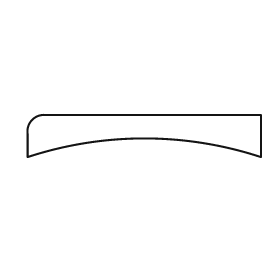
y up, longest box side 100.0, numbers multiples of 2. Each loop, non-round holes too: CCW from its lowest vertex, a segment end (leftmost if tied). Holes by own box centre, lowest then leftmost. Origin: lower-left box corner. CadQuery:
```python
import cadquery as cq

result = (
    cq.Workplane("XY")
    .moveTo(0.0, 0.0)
    .threePointArc((50.0, 8.0), (100.0, 0.0))
    .lineTo(100.0, 18.0)
    .lineTo(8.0, 18.0)
    .threePointArc((2.0, 16.0), (0.0, 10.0))
    .close()
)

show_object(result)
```